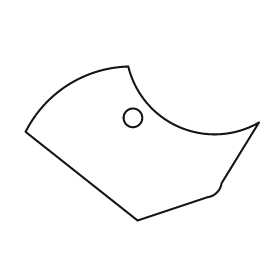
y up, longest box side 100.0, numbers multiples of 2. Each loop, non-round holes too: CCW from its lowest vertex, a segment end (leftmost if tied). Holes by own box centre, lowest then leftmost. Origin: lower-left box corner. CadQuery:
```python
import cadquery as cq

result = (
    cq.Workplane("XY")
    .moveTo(48.0, 0.0)
    .lineTo(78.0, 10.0)
    .threePointArc((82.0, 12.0), (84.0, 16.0))
    .lineTo(100.0, 42.0)
    .threePointArc((66.0, 40.0), (44.0, 66.0))
    .threePointArc((18.0, 58.0), (0.0, 38.0))
    .close()
    .moveTo(46.0, 44.0)
    .circle(4.0)
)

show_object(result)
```